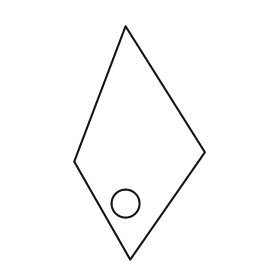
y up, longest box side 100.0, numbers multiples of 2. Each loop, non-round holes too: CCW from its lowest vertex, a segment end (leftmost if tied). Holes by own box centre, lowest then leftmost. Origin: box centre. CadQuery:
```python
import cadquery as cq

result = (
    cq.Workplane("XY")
    .moveTo(-4.0, -50.0)
    .lineTo(28.0, -4.0)
    .lineTo(-6.0, 50.0)
    .lineTo(-28.0, -8.0)
    .close()
    .moveTo(-6.0, -26.0)
    .circle(6.0)
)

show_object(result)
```